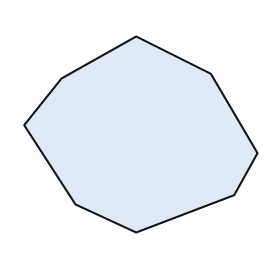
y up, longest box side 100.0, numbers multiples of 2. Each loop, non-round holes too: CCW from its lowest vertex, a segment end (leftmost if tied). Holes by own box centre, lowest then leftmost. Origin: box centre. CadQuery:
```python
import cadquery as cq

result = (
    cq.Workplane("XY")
    .moveTo(-2.0, -42.0)
    .lineTo(40.0, -26.0)
    .lineTo(50.0, -8.0)
    .lineTo(30.0, 26.0)
    .lineTo(-2.0, 42.0)
    .lineTo(-34.0, 24.0)
    .lineTo(-50.0, 4.0)
    .lineTo(-28.0, -30.0)
    .close()
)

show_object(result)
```